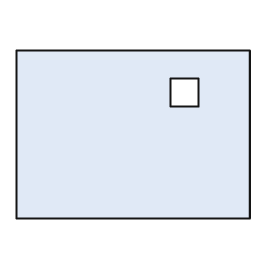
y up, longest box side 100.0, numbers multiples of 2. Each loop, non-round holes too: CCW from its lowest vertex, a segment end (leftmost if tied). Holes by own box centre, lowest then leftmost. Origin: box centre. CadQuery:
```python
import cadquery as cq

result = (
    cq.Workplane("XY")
    .moveTo(-50.0, -36.0)
    .lineTo(50.0, -36.0)
    .lineTo(50.0, 36.0)
    .lineTo(-50.0, 36.0)
    .close()
    .moveTo(16.0, 12.0)
    .lineTo(28.0, 12.0)
    .lineTo(28.0, 24.0)
    .lineTo(16.0, 24.0)
    .close()
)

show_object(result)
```